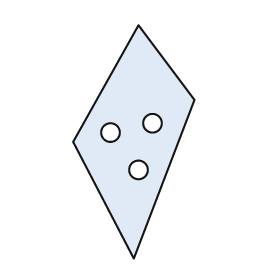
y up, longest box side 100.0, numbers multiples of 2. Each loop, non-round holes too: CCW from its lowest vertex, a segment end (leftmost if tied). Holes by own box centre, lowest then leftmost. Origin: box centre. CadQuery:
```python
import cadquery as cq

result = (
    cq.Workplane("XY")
    .moveTo(0.0, -50.0)
    .lineTo(26.0, 18.0)
    .lineTo(2.0, 50.0)
    .lineTo(-26.0, 0.0)
    .close()
    .moveTo(2.0, -12.0)
    .circle(4.0)
    .moveTo(-10.0, 4.0)
    .circle(4.0)
    .moveTo(8.0, 8.0)
    .circle(4.0)
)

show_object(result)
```